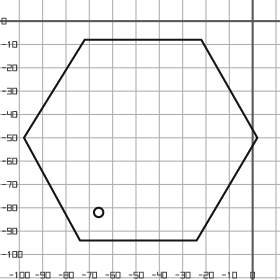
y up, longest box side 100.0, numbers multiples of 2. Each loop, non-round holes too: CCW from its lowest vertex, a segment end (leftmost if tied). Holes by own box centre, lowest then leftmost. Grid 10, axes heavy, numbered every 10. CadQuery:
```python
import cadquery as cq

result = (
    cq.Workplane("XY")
    .moveTo(-74.0, -94.0)
    .lineTo(-24.0, -94.0)
    .lineTo(2.0, -50.0)
    .lineTo(-22.0, -8.0)
    .lineTo(-72.0, -8.0)
    .lineTo(-98.0, -50.0)
    .close()
    .moveTo(-66.0, -82.0)
    .circle(2.0)
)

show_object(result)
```